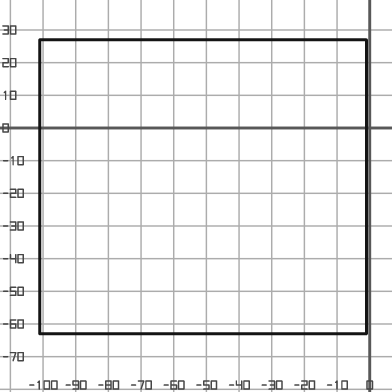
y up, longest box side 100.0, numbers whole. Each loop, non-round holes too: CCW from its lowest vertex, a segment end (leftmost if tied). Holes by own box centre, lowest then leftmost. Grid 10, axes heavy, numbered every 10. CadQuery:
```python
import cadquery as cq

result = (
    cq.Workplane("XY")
    .moveTo(-101.0, -63.0)
    .lineTo(-1.0, -63.0)
    .lineTo(-1.0, 27.0)
    .lineTo(-101.0, 27.0)
    .close()
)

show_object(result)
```